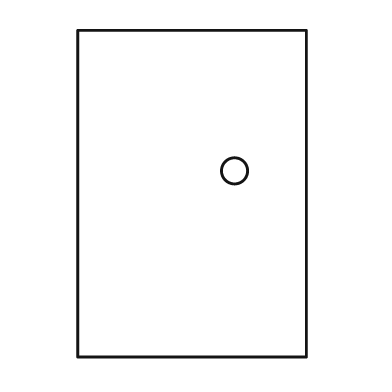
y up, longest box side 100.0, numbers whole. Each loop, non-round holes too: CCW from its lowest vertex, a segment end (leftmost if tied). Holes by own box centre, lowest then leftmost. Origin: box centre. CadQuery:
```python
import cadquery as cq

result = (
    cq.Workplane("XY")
    .moveTo(-35.0, -50.0)
    .lineTo(35.0, -50.0)
    .lineTo(35.0, 50.0)
    .lineTo(-35.0, 50.0)
    .close()
    .moveTo(13.0, 7.0)
    .circle(4.0)
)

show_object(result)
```